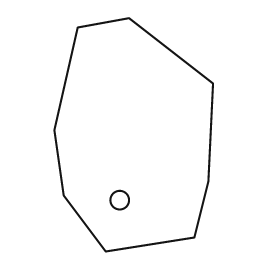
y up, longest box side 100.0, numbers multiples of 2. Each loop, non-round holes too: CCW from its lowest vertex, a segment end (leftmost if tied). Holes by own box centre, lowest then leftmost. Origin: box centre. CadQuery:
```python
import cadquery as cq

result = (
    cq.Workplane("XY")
    .moveTo(-12.0, -50.0)
    .lineTo(26.0, -44.0)
    .lineTo(32.0, -20.0)
    .lineTo(34.0, 22.0)
    .lineTo(-2.0, 50.0)
    .lineTo(-24.0, 46.0)
    .lineTo(-34.0, 2.0)
    .lineTo(-30.0, -26.0)
    .close()
    .moveTo(-6.0, -28.0)
    .circle(4.0)
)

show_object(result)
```